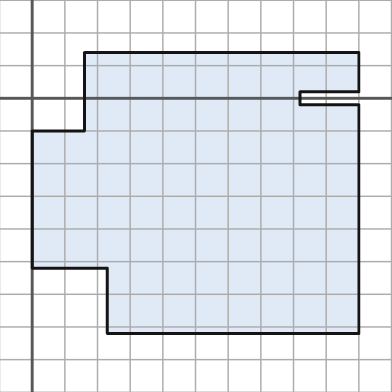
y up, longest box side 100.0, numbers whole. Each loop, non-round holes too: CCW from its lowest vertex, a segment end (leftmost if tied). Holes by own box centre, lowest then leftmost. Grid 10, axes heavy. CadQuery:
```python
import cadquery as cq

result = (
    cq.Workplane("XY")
    .moveTo(23.0, -72.0)
    .lineTo(100.0, -72.0)
    .lineTo(100.0, -2.0)
    .lineTo(82.0, -2.0)
    .lineTo(82.0, 2.0)
    .lineTo(100.0, 2.0)
    .lineTo(100.0, 14.0)
    .lineTo(16.0, 14.0)
    .lineTo(16.0, -10.0)
    .lineTo(0.0, -10.0)
    .lineTo(0.0, -52.0)
    .lineTo(23.0, -52.0)
    .close()
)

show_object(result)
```